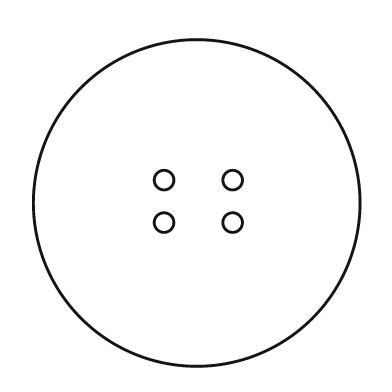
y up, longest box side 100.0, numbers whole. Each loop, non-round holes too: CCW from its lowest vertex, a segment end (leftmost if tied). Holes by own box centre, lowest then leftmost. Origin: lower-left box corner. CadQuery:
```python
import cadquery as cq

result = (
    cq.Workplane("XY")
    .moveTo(50.0, 50.0)
    .circle(50.0)
    .moveTo(40.0, 44.0)
    .circle(3.0)
    .moveTo(61.0, 44.0)
    .circle(3.0)
    .moveTo(40.0, 57.0)
    .circle(3.0)
    .moveTo(61.0, 57.0)
    .circle(3.0)
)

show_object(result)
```